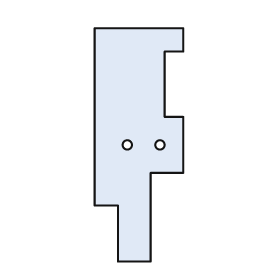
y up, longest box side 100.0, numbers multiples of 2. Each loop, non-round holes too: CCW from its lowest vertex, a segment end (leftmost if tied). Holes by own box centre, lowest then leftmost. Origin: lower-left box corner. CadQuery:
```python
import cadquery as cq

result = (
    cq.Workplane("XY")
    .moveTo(10.0, 0.0)
    .lineTo(24.0, 0.0)
    .lineTo(24.0, 38.0)
    .lineTo(38.0, 38.0)
    .lineTo(38.0, 62.0)
    .lineTo(30.0, 62.0)
    .lineTo(30.0, 90.0)
    .lineTo(38.0, 90.0)
    .lineTo(38.0, 100.0)
    .lineTo(0.0, 100.0)
    .lineTo(0.0, 24.0)
    .lineTo(10.0, 24.0)
    .close()
    .moveTo(14.0, 50.0)
    .circle(2.0)
    .moveTo(28.0, 50.0)
    .circle(2.0)
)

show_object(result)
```